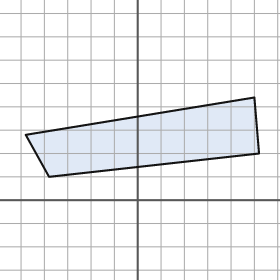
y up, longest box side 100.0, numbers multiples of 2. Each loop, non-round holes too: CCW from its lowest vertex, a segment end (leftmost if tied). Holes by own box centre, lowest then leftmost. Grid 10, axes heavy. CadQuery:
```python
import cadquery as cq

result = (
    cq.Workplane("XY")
    .moveTo(-38.0, 10.0)
    .lineTo(52.0, 20.0)
    .lineTo(50.0, 44.0)
    .lineTo(-48.0, 28.0)
    .close()
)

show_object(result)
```